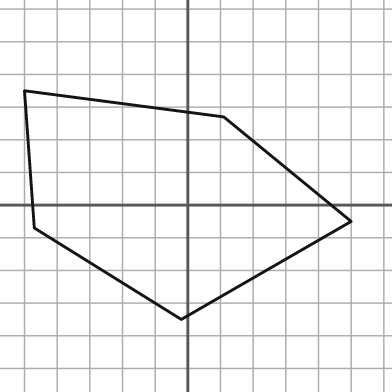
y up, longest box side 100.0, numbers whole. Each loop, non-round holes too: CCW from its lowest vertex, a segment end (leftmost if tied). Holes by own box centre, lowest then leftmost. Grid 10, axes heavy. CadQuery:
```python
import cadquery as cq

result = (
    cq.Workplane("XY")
    .moveTo(-2.0, -35.0)
    .lineTo(50.0, -5.0)
    .lineTo(11.0, 27.0)
    .lineTo(-50.0, 35.0)
    .lineTo(-47.0, -7.0)
    .close()
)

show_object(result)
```